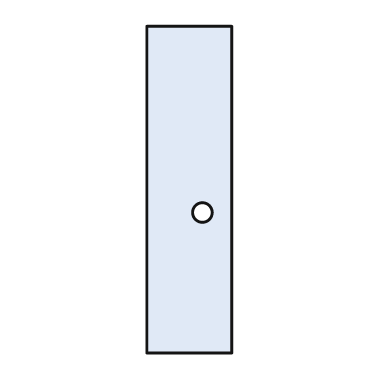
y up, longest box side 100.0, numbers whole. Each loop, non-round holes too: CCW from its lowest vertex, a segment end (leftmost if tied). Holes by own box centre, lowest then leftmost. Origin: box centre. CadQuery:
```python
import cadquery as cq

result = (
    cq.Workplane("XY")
    .moveTo(-13.0, -50.0)
    .lineTo(13.0, -50.0)
    .lineTo(13.0, 50.0)
    .lineTo(-13.0, 50.0)
    .close()
    .moveTo(4.0, -7.0)
    .circle(3.0)
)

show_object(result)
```